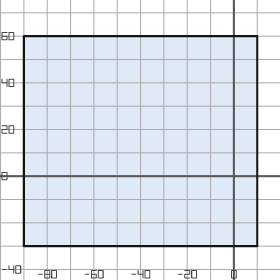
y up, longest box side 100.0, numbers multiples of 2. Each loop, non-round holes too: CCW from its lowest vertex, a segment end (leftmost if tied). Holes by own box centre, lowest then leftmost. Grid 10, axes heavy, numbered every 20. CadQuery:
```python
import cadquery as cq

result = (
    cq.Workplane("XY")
    .moveTo(-90.0, -30.0)
    .lineTo(10.0, -30.0)
    .lineTo(10.0, 60.0)
    .lineTo(-90.0, 60.0)
    .close()
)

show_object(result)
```